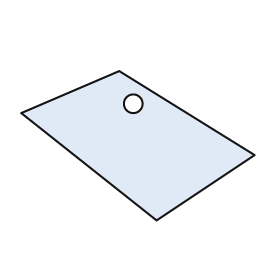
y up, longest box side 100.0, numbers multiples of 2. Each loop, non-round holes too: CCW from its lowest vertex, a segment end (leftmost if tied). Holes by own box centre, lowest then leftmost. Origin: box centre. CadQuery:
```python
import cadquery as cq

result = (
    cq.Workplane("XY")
    .moveTo(8.0, -32.0)
    .lineTo(50.0, -4.0)
    .lineTo(-8.0, 32.0)
    .lineTo(-50.0, 14.0)
    .close()
    .moveTo(-2.0, 18.0)
    .circle(4.0)
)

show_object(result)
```